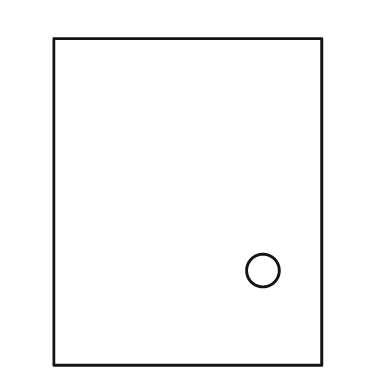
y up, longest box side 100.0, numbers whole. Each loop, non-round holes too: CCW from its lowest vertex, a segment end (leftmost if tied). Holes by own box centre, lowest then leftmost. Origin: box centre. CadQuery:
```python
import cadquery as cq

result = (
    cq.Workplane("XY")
    .moveTo(-41.0, -50.0)
    .lineTo(41.0, -50.0)
    .lineTo(41.0, 50.0)
    .lineTo(-41.0, 50.0)
    .close()
    .moveTo(23.0, -21.0)
    .circle(5.0)
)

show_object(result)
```